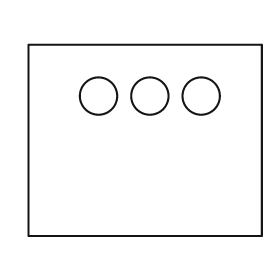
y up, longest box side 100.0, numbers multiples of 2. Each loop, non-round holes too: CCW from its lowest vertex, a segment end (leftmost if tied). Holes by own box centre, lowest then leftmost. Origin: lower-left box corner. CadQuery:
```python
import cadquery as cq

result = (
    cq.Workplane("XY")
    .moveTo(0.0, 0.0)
    .lineTo(100.0, 0.0)
    .lineTo(100.0, 82.0)
    .lineTo(0.0, 82.0)
    .close()
    .moveTo(30.0, 60.0)
    .circle(8.0)
    .moveTo(52.0, 60.0)
    .circle(8.0)
    .moveTo(74.0, 60.0)
    .circle(8.0)
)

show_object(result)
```